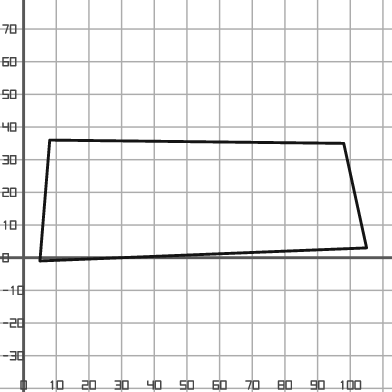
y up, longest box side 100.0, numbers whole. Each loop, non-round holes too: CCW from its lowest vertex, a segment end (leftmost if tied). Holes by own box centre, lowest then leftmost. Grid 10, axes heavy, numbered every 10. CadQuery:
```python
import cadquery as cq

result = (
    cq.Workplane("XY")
    .moveTo(5.0, -1.0)
    .lineTo(105.0, 3.0)
    .lineTo(98.0, 35.0)
    .lineTo(8.0, 36.0)
    .close()
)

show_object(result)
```